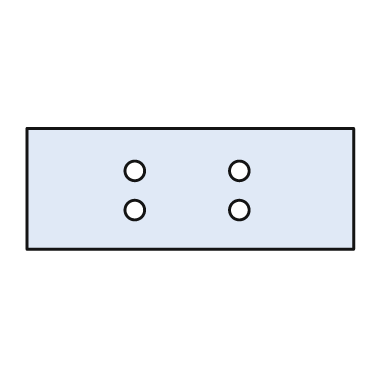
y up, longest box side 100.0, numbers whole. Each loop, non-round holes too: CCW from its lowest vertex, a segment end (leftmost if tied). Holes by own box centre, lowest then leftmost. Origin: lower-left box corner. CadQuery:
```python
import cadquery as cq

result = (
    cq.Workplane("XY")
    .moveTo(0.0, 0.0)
    .lineTo(100.0, 0.0)
    .lineTo(100.0, 37.0)
    .lineTo(0.0, 37.0)
    .close()
    .moveTo(33.0, 12.0)
    .circle(3.0)
    .moveTo(65.0, 12.0)
    .circle(3.0)
    .moveTo(33.0, 24.0)
    .circle(3.0)
    .moveTo(65.0, 24.0)
    .circle(3.0)
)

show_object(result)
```